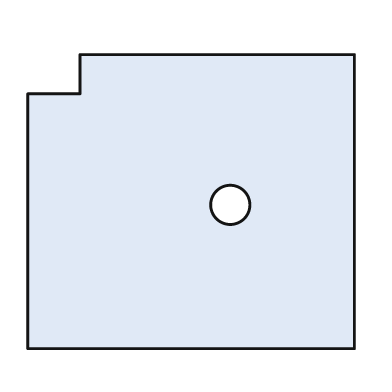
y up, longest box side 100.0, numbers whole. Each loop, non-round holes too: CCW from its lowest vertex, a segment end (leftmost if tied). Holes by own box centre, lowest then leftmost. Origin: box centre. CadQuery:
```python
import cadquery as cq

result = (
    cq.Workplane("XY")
    .moveTo(-50.0, -45.0)
    .lineTo(50.0, -45.0)
    .lineTo(50.0, 45.0)
    .lineTo(-34.0, 45.0)
    .lineTo(-34.0, 33.0)
    .lineTo(-50.0, 33.0)
    .close()
    .moveTo(12.0, -1.0)
    .circle(6.0)
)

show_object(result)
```